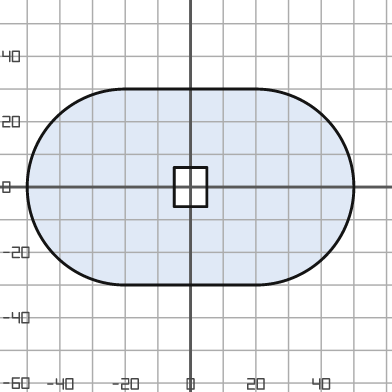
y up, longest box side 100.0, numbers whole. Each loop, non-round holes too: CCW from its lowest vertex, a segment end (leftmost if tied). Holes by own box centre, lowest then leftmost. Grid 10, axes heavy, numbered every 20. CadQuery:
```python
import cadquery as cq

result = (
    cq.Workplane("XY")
    .moveTo(-20.0, -30.0)
    .lineTo(20.0, -30.0)
    .threePointArc((50.0, 0.0), (20.0, 30.0))
    .lineTo(-20.0, 30.0)
    .threePointArc((-50.0, 0.0), (-20.0, -30.0))
    .close()
    .moveTo(-5.0, -6.0)
    .lineTo(5.0, -6.0)
    .lineTo(5.0, 6.0)
    .lineTo(-5.0, 6.0)
    .close()
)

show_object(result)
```